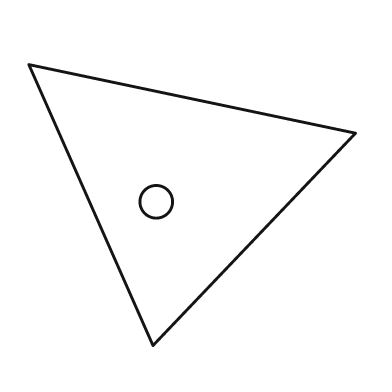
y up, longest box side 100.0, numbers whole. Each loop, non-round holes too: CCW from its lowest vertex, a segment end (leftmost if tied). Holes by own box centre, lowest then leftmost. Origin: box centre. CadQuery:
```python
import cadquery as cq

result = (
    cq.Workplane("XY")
    .moveTo(-12.0, -43.0)
    .lineTo(50.0, 22.0)
    .lineTo(-50.0, 43.0)
    .close()
    .moveTo(-11.0, 1.0)
    .circle(5.0)
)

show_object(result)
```